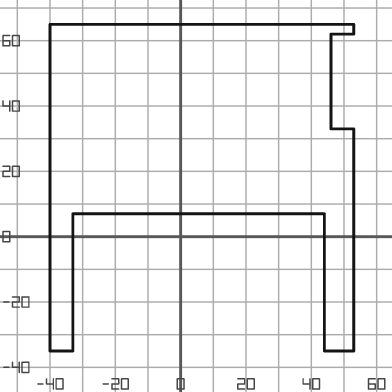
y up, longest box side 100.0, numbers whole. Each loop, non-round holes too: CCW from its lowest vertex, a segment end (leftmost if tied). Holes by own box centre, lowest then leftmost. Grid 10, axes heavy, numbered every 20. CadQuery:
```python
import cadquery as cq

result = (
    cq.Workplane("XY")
    .moveTo(-40.0, -35.0)
    .lineTo(-33.0, -35.0)
    .lineTo(-33.0, 7.0)
    .lineTo(44.0, 7.0)
    .lineTo(44.0, -35.0)
    .lineTo(53.0, -35.0)
    .lineTo(53.0, 33.0)
    .lineTo(46.0, 33.0)
    .lineTo(46.0, 62.0)
    .lineTo(53.0, 62.0)
    .lineTo(53.0, 65.0)
    .lineTo(-40.0, 65.0)
    .close()
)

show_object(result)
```